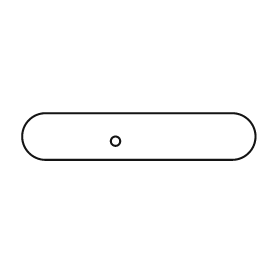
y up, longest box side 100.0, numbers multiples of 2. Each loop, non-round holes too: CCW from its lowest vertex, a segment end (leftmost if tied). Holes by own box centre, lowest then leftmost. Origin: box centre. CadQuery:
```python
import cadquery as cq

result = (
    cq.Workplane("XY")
    .moveTo(-40.0, -10.0)
    .lineTo(40.0, -10.0)
    .threePointArc((50.0, 0.0), (40.0, 10.0))
    .lineTo(-40.0, 10.0)
    .threePointArc((-50.0, 0.0), (-40.0, -10.0))
    .close()
    .moveTo(-10.0, -2.0)
    .circle(2.0)
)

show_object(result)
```